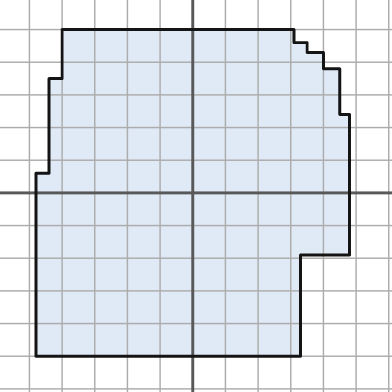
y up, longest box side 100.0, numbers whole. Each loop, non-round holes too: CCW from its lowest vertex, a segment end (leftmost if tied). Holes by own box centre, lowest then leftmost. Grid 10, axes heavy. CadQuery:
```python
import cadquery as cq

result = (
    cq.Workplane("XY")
    .moveTo(-48.0, -50.0)
    .lineTo(33.0, -50.0)
    .lineTo(33.0, -19.0)
    .lineTo(48.0, -19.0)
    .lineTo(48.0, 24.0)
    .lineTo(45.0, 24.0)
    .lineTo(45.0, 38.0)
    .lineTo(40.0, 38.0)
    .lineTo(40.0, 43.0)
    .lineTo(35.0, 43.0)
    .lineTo(35.0, 46.0)
    .lineTo(31.0, 46.0)
    .lineTo(31.0, 50.0)
    .lineTo(-40.0, 50.0)
    .lineTo(-40.0, 35.0)
    .lineTo(-44.0, 35.0)
    .lineTo(-44.0, 6.0)
    .lineTo(-48.0, 6.0)
    .close()
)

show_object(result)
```